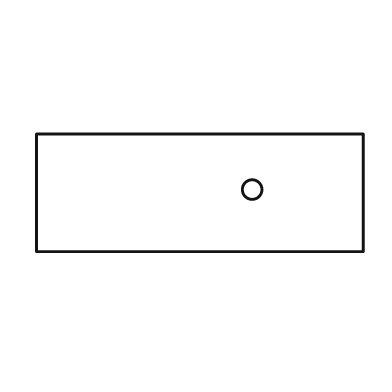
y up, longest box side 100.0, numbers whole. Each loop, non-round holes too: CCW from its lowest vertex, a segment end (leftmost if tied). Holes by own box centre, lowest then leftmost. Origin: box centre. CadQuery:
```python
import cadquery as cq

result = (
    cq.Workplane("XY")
    .moveTo(-50.0, -18.0)
    .lineTo(50.0, -18.0)
    .lineTo(50.0, 18.0)
    .lineTo(-50.0, 18.0)
    .close()
    .moveTo(16.0, 1.0)
    .circle(3.0)
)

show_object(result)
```